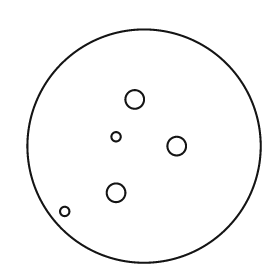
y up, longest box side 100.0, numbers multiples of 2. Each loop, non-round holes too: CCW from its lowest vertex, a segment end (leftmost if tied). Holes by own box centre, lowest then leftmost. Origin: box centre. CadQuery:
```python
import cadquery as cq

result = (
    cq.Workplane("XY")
    .moveTo(0.0, 0.0)
    .circle(50.0)
    .moveTo(-34.0, -28.0)
    .circle(2.0)
    .moveTo(-12.0, -20.0)
    .circle(4.0)
    .moveTo(14.0, 0.0)
    .circle(4.0)
    .moveTo(-12.0, 4.0)
    .circle(2.0)
    .moveTo(-4.0, 20.0)
    .circle(4.0)
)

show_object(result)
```